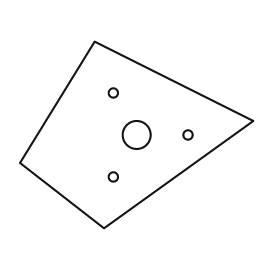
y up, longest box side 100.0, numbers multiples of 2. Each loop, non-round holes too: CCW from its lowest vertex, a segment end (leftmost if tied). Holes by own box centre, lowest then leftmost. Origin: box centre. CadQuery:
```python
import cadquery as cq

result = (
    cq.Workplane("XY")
    .moveTo(-14.0, -40.0)
    .lineTo(50.0, 6.0)
    .lineTo(-18.0, 40.0)
    .lineTo(-50.0, -12.0)
    .close()
    .moveTo(-10.0, -18.0)
    .circle(2.0)
    .moveTo(0.0, 0.0)
    .circle(6.0)
    .moveTo(22.0, 0.0)
    .circle(2.0)
    .moveTo(-10.0, 18.0)
    .circle(2.0)
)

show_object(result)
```